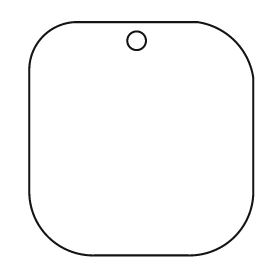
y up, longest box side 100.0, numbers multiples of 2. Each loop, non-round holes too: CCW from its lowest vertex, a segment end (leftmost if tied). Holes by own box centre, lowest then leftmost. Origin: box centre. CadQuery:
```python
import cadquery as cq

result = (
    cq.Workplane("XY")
    .moveTo(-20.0, -50.0)
    .lineTo(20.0, -50.0)
    .threePointArc((40.0, -42.0), (48.0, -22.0))
    .lineTo(48.0, 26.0)
    .threePointArc((40.0, 42.0), (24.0, 50.0))
    .lineTo(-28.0, 50.0)
    .threePointArc((-42.0, 44.0), (-48.0, 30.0))
    .lineTo(-48.0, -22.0)
    .threePointArc((-40.0, -42.0), (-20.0, -50.0))
    .close()
    .moveTo(-2.0, 42.0)
    .circle(4.0)
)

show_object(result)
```